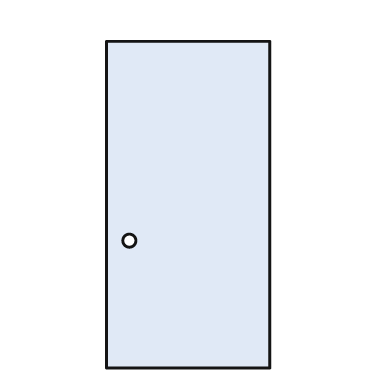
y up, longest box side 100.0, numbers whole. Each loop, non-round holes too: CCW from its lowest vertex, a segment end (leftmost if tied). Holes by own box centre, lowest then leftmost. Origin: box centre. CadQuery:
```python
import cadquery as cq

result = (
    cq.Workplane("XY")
    .moveTo(-25.0, -50.0)
    .lineTo(25.0, -50.0)
    .lineTo(25.0, 50.0)
    .lineTo(-25.0, 50.0)
    .close()
    .moveTo(-18.0, -11.0)
    .circle(2.0)
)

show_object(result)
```